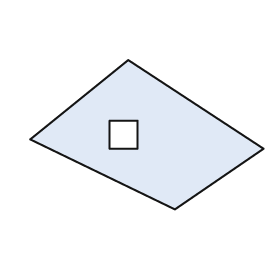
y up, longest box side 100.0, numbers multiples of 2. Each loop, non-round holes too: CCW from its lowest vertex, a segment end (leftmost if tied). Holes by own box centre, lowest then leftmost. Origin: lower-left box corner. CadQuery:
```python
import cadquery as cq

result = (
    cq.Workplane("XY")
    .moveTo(62.0, 0.0)
    .lineTo(100.0, 26.0)
    .lineTo(42.0, 64.0)
    .lineTo(0.0, 30.0)
    .close()
    .moveTo(34.0, 26.0)
    .lineTo(46.0, 26.0)
    .lineTo(46.0, 38.0)
    .lineTo(34.0, 38.0)
    .close()
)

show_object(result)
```